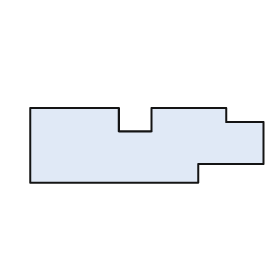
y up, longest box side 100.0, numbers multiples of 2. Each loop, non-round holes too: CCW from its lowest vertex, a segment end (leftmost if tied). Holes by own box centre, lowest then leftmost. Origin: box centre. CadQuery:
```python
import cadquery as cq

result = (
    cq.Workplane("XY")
    .moveTo(-50.0, -16.0)
    .lineTo(22.0, -16.0)
    .lineTo(22.0, -8.0)
    .lineTo(50.0, -8.0)
    .lineTo(50.0, 10.0)
    .lineTo(34.0, 10.0)
    .lineTo(34.0, 16.0)
    .lineTo(2.0, 16.0)
    .lineTo(2.0, 6.0)
    .lineTo(-12.0, 6.0)
    .lineTo(-12.0, 16.0)
    .lineTo(-50.0, 16.0)
    .close()
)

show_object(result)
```